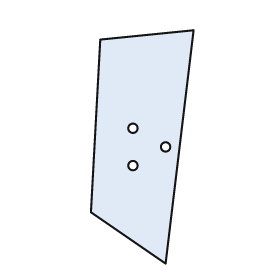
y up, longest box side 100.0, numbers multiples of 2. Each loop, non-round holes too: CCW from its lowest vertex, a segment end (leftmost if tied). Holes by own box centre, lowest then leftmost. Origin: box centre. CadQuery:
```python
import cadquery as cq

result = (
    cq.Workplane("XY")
    .moveTo(10.0, -50.0)
    .lineTo(22.0, 50.0)
    .lineTo(-18.0, 46.0)
    .lineTo(-22.0, -28.0)
    .close()
    .moveTo(-4.0, -8.0)
    .circle(2.0)
    .moveTo(10.0, 0.0)
    .circle(2.0)
    .moveTo(-4.0, 8.0)
    .circle(2.0)
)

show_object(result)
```